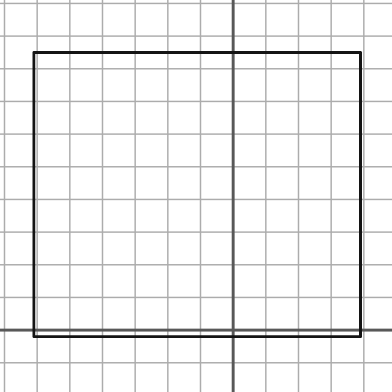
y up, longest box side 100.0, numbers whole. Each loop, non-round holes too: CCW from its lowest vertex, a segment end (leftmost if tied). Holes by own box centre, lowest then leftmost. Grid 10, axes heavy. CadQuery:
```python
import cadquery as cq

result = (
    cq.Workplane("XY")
    .moveTo(-61.0, -2.0)
    .lineTo(39.0, -2.0)
    .lineTo(39.0, 85.0)
    .lineTo(-61.0, 85.0)
    .close()
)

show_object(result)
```